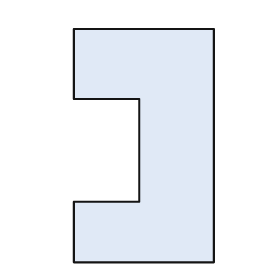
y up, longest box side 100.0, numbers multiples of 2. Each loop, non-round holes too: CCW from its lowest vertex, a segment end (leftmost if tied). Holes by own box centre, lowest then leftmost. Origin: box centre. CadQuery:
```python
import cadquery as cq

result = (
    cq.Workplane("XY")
    .moveTo(-30.0, -50.0)
    .lineTo(30.0, -50.0)
    .lineTo(30.0, 50.0)
    .lineTo(-30.0, 50.0)
    .lineTo(-30.0, 20.0)
    .lineTo(-2.0, 20.0)
    .lineTo(-2.0, -24.0)
    .lineTo(-30.0, -24.0)
    .close()
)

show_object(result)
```